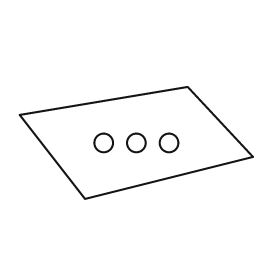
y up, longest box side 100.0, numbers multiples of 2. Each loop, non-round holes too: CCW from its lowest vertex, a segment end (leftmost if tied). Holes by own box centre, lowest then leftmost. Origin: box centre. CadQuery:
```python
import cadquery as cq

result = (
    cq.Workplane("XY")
    .moveTo(-22.0, -24.0)
    .lineTo(50.0, -6.0)
    .lineTo(22.0, 24.0)
    .lineTo(-50.0, 12.0)
    .close()
    .moveTo(-14.0, 0.0)
    .circle(4.0)
    .moveTo(0.0, 0.0)
    .circle(4.0)
    .moveTo(14.0, 0.0)
    .circle(4.0)
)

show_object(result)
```